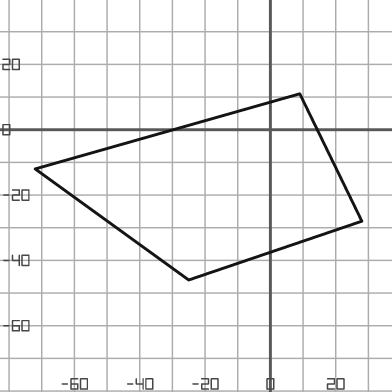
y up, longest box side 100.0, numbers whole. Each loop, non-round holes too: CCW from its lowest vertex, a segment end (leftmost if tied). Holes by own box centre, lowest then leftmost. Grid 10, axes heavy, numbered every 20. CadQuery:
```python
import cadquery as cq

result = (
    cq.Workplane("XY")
    .moveTo(-25.0, -46.0)
    .lineTo(28.0, -28.0)
    .lineTo(9.0, 11.0)
    .lineTo(-72.0, -12.0)
    .close()
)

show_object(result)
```